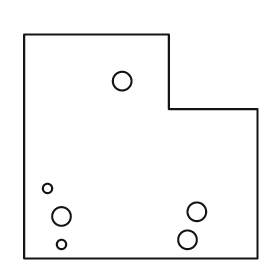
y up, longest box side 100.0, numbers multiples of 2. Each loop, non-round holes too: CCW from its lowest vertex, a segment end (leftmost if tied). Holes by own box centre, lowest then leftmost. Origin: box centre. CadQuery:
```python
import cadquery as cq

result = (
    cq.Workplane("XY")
    .moveTo(-50.0, -48.0)
    .lineTo(50.0, -48.0)
    .lineTo(50.0, 16.0)
    .lineTo(12.0, 16.0)
    .lineTo(12.0, 48.0)
    .lineTo(-50.0, 48.0)
    .close()
    .moveTo(-34.0, -42.0)
    .circle(2.0)
    .moveTo(20.0, -40.0)
    .circle(4.0)
    .moveTo(-34.0, -30.0)
    .circle(4.0)
    .moveTo(24.0, -28.0)
    .circle(4.0)
    .moveTo(-40.0, -18.0)
    .circle(2.0)
    .moveTo(-8.0, 28.0)
    .circle(4.0)
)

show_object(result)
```